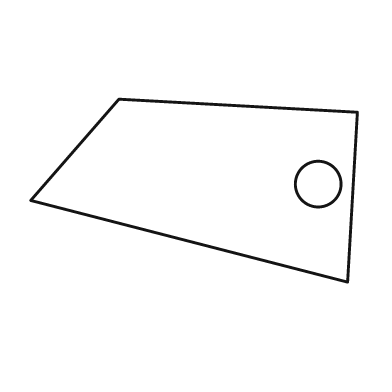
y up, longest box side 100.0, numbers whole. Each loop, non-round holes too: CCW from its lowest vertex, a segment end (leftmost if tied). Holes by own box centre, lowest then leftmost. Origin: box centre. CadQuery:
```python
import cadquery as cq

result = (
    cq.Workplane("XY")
    .moveTo(47.0, -28.0)
    .lineTo(50.0, 24.0)
    .lineTo(-23.0, 28.0)
    .lineTo(-50.0, -3.0)
    .close()
    .moveTo(38.0, 2.0)
    .circle(7.0)
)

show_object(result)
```